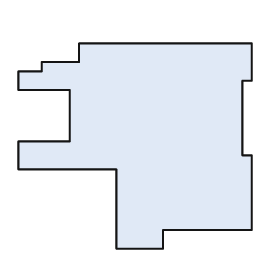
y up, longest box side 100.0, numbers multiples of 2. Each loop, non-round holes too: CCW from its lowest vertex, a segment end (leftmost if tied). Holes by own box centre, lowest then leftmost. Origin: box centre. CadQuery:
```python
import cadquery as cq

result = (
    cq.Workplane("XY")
    .moveTo(-8.0, -44.0)
    .lineTo(12.0, -44.0)
    .lineTo(12.0, -36.0)
    .lineTo(50.0, -36.0)
    .lineTo(50.0, -4.0)
    .lineTo(46.0, -4.0)
    .lineTo(46.0, 28.0)
    .lineTo(50.0, 28.0)
    .lineTo(50.0, 44.0)
    .lineTo(-24.0, 44.0)
    .lineTo(-24.0, 36.0)
    .lineTo(-40.0, 36.0)
    .lineTo(-40.0, 32.0)
    .lineTo(-50.0, 32.0)
    .lineTo(-50.0, 24.0)
    .lineTo(-28.0, 24.0)
    .lineTo(-28.0, 2.0)
    .lineTo(-50.0, 2.0)
    .lineTo(-50.0, -10.0)
    .lineTo(-8.0, -10.0)
    .close()
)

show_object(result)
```